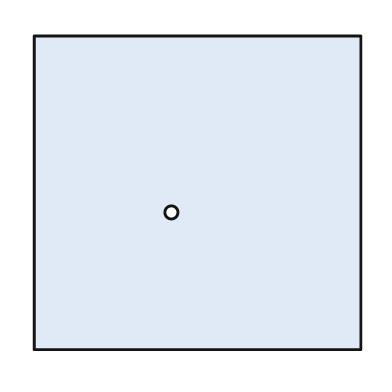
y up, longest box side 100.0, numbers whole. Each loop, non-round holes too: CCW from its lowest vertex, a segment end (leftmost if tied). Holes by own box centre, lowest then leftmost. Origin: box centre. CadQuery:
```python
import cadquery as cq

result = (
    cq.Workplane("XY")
    .moveTo(-50.0, -48.0)
    .lineTo(50.0, -48.0)
    .lineTo(50.0, 48.0)
    .lineTo(-50.0, 48.0)
    .close()
    .moveTo(-8.0, -6.0)
    .circle(2.0)
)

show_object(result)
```